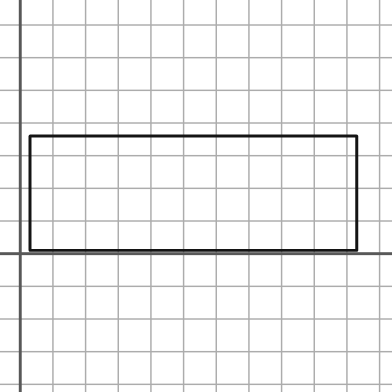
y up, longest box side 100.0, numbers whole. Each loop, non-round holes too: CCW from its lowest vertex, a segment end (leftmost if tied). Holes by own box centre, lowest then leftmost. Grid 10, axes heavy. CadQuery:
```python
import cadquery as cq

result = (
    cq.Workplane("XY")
    .moveTo(3.0, 1.0)
    .lineTo(103.0, 1.0)
    .lineTo(103.0, 36.0)
    .lineTo(3.0, 36.0)
    .close()
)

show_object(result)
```